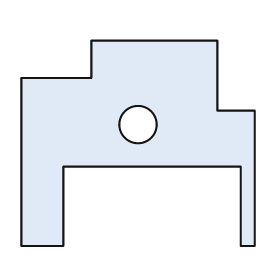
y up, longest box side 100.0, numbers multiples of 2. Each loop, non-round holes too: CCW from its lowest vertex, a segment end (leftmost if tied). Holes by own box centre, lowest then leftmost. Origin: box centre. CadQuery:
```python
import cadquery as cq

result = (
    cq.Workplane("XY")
    .moveTo(-50.0, -44.0)
    .lineTo(-32.0, -44.0)
    .lineTo(-32.0, -10.0)
    .lineTo(44.0, -10.0)
    .lineTo(44.0, -44.0)
    .lineTo(50.0, -44.0)
    .lineTo(50.0, 14.0)
    .lineTo(34.0, 14.0)
    .lineTo(34.0, 44.0)
    .lineTo(-20.0, 44.0)
    .lineTo(-20.0, 28.0)
    .lineTo(-50.0, 28.0)
    .close()
    .moveTo(0.0, 8.0)
    .circle(8.0)
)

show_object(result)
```